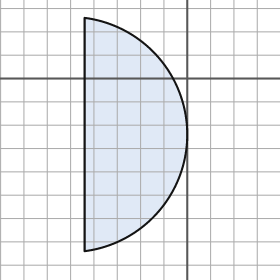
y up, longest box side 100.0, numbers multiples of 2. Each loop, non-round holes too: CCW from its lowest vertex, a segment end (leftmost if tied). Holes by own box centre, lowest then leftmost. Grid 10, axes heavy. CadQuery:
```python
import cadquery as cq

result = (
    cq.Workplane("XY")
    .moveTo(-44.0, -74.0)
    .threePointArc((0.0, -24.0), (-44.0, 26.0))
    .close()
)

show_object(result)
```